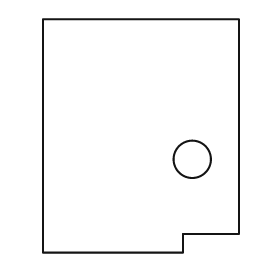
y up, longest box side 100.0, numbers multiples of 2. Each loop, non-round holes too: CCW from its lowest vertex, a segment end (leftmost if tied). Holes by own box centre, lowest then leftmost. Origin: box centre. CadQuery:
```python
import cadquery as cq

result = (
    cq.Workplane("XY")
    .moveTo(-42.0, -50.0)
    .lineTo(18.0, -50.0)
    .lineTo(18.0, -42.0)
    .lineTo(42.0, -42.0)
    .lineTo(42.0, 50.0)
    .lineTo(-42.0, 50.0)
    .close()
    .moveTo(22.0, -10.0)
    .circle(8.0)
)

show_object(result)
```